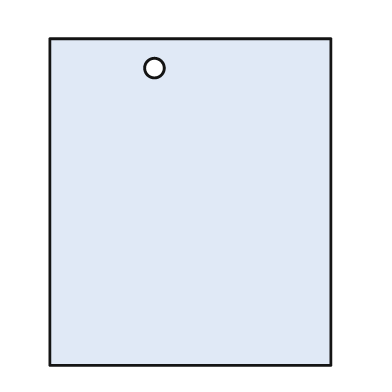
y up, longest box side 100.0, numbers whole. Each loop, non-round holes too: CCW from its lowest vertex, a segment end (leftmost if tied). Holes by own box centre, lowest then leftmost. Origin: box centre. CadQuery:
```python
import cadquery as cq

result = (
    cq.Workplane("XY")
    .moveTo(-43.0, -50.0)
    .lineTo(43.0, -50.0)
    .lineTo(43.0, 50.0)
    .lineTo(-43.0, 50.0)
    .close()
    .moveTo(-11.0, 41.0)
    .circle(3.0)
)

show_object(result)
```